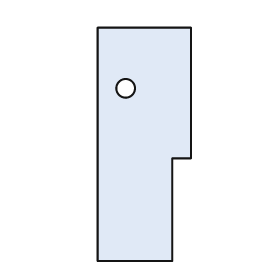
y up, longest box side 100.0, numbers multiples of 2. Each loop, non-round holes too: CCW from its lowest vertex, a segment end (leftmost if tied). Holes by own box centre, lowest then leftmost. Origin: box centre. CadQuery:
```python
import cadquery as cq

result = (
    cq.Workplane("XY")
    .moveTo(-20.0, -50.0)
    .lineTo(12.0, -50.0)
    .lineTo(12.0, -6.0)
    .lineTo(20.0, -6.0)
    .lineTo(20.0, 50.0)
    .lineTo(-20.0, 50.0)
    .close()
    .moveTo(-8.0, 24.0)
    .circle(4.0)
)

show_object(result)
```